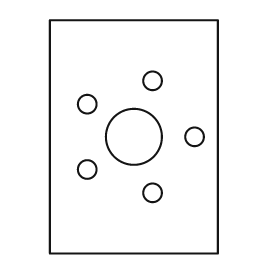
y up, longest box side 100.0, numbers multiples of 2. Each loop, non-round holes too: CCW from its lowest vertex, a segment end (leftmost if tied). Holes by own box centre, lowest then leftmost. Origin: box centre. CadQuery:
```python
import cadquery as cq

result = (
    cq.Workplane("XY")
    .moveTo(-36.0, -50.0)
    .lineTo(36.0, -50.0)
    .lineTo(36.0, 50.0)
    .lineTo(-36.0, 50.0)
    .close()
    .moveTo(8.0, -24.0)
    .circle(4.0)
    .moveTo(-20.0, -14.0)
    .circle(4.0)
    .moveTo(0.0, 0.0)
    .circle(12.0)
    .moveTo(26.0, 0.0)
    .circle(4.0)
    .moveTo(-20.0, 14.0)
    .circle(4.0)
    .moveTo(8.0, 24.0)
    .circle(4.0)
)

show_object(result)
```